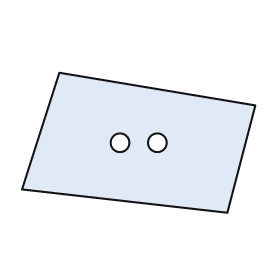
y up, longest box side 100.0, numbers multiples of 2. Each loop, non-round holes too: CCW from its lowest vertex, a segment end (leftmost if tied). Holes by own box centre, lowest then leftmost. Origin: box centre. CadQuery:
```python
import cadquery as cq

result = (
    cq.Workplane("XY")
    .moveTo(38.0, -30.0)
    .lineTo(50.0, 16.0)
    .lineTo(-34.0, 30.0)
    .lineTo(-50.0, -20.0)
    .close()
    .moveTo(-8.0, 0.0)
    .circle(4.0)
    .moveTo(8.0, 0.0)
    .circle(4.0)
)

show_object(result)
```